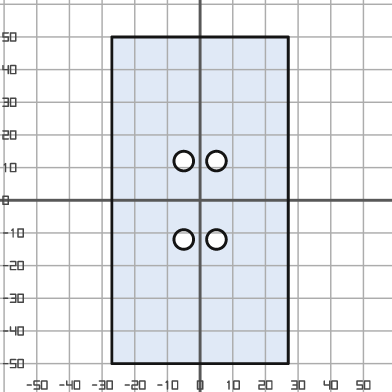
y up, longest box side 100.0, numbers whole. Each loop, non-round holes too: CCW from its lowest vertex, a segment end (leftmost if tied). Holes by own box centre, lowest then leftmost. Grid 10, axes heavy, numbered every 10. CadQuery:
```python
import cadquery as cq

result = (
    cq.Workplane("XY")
    .moveTo(-27.0, -50.0)
    .lineTo(27.0, -50.0)
    .lineTo(27.0, 50.0)
    .lineTo(-27.0, 50.0)
    .close()
    .moveTo(-5.0, -12.0)
    .circle(3.0)
    .moveTo(5.0, -12.0)
    .circle(3.0)
    .moveTo(-5.0, 12.0)
    .circle(3.0)
    .moveTo(5.0, 12.0)
    .circle(3.0)
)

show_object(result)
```